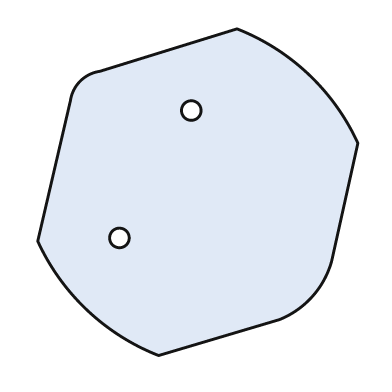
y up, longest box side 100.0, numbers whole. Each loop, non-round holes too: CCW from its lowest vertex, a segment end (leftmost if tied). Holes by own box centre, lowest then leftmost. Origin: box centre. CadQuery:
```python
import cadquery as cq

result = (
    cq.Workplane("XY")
    .moveTo(-12.0, -50.0)
    .lineTo(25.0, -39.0)
    .threePointArc((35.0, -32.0), (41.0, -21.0))
    .lineTo(49.0, 15.0)
    .threePointArc((34.0, 36.0), (12.0, 50.0))
    .lineTo(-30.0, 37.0)
    .threePointArc((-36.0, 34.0), (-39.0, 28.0))
    .lineTo(-49.0, -15.0)
    .threePointArc((-34.0, -36.0), (-12.0, -50.0))
    .close()
    .moveTo(-24.0, -14.0)
    .circle(3.0)
    .moveTo(-2.0, 25.0)
    .circle(3.0)
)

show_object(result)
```